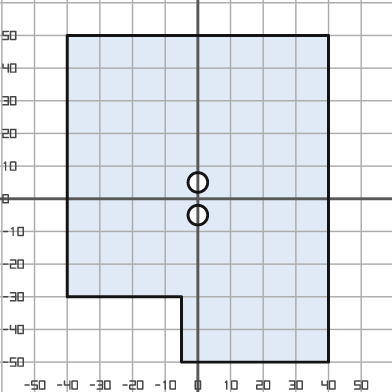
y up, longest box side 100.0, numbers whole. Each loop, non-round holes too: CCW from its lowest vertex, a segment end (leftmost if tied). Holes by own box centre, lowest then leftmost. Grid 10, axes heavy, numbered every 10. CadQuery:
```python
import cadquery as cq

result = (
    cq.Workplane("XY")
    .moveTo(-5.0, -50.0)
    .lineTo(40.0, -50.0)
    .lineTo(40.0, 50.0)
    .lineTo(-40.0, 50.0)
    .lineTo(-40.0, -30.0)
    .lineTo(-5.0, -30.0)
    .close()
    .moveTo(0.0, -5.0)
    .circle(3.0)
    .moveTo(0.0, 5.0)
    .circle(3.0)
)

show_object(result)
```